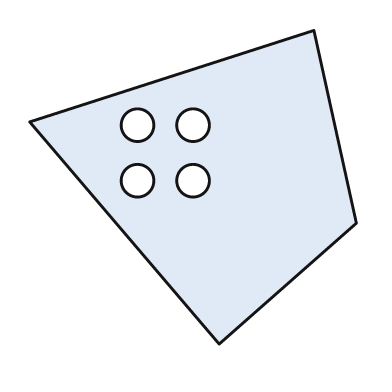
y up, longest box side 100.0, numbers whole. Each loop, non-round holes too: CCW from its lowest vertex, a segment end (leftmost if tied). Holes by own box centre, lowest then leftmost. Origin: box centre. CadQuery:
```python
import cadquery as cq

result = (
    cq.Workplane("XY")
    .moveTo(8.0, -48.0)
    .lineTo(50.0, -11.0)
    .lineTo(37.0, 48.0)
    .lineTo(-50.0, 20.0)
    .close()
    .moveTo(-17.0, 2.0)
    .circle(5.0)
    .moveTo(0.0, 2.0)
    .circle(5.0)
    .moveTo(-17.0, 19.0)
    .circle(5.0)
    .moveTo(0.0, 19.0)
    .circle(5.0)
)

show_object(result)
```